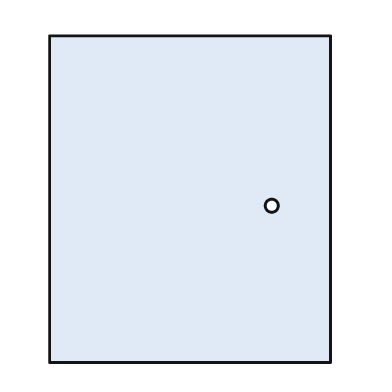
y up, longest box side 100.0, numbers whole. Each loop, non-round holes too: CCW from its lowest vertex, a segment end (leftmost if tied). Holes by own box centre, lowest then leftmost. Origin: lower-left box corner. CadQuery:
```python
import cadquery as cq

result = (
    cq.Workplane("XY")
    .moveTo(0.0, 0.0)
    .lineTo(86.0, 0.0)
    .lineTo(86.0, 100.0)
    .lineTo(0.0, 100.0)
    .close()
    .moveTo(68.0, 48.0)
    .circle(2.0)
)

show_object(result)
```